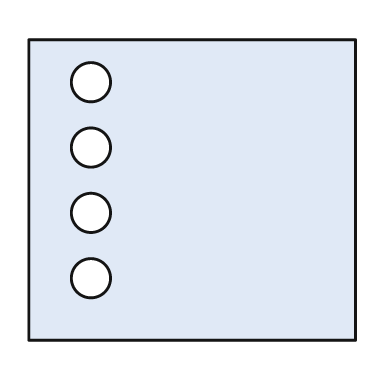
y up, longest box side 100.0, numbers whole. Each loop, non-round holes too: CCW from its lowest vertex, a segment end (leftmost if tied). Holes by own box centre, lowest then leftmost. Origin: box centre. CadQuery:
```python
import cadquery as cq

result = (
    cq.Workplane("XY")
    .moveTo(-50.0, -46.0)
    .lineTo(50.0, -46.0)
    .lineTo(50.0, 46.0)
    .lineTo(-50.0, 46.0)
    .close()
    .moveTo(-31.0, -27.0)
    .circle(6.0)
    .moveTo(-31.0, -7.0)
    .circle(6.0)
    .moveTo(-31.0, 13.0)
    .circle(6.0)
    .moveTo(-31.0, 33.0)
    .circle(6.0)
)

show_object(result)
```